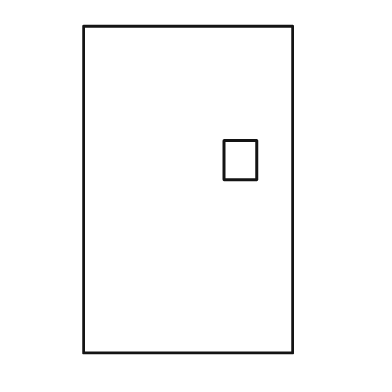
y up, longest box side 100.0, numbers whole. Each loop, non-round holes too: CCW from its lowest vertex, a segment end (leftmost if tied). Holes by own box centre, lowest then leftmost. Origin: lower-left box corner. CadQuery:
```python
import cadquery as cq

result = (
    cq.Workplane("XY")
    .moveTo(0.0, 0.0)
    .lineTo(64.0, 0.0)
    .lineTo(64.0, 100.0)
    .lineTo(0.0, 100.0)
    .close()
    .moveTo(43.0, 53.0)
    .lineTo(53.0, 53.0)
    .lineTo(53.0, 65.0)
    .lineTo(43.0, 65.0)
    .close()
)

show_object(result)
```